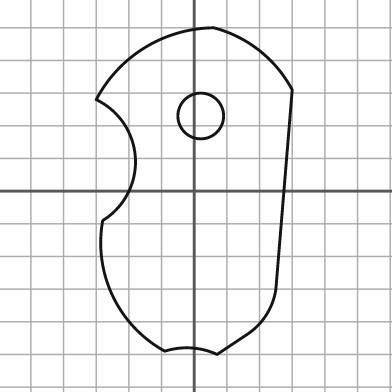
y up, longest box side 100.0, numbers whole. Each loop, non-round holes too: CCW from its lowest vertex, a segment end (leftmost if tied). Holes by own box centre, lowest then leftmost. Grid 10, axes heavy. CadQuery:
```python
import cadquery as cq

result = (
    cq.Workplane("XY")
    .moveTo(7.0, -50.0)
    .lineTo(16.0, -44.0)
    .threePointArc((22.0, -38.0), (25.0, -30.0))
    .lineTo(30.0, 31.0)
    .threePointArc((20.0, 43.0), (6.0, 50.0))
    .threePointArc((-15.0, 44.0), (-30.0, 28.0))
    .threePointArc((-18.0, 10.0), (-28.0, -9.0))
    .threePointArc((-25.0, -32.0), (-9.0, -49.0))
    .threePointArc((-1.0, -48.0), (7.0, -50.0))
    .close()
    .moveTo(2.0, 23.0)
    .circle(7.0)
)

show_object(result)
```